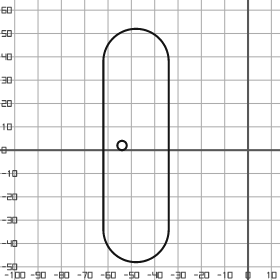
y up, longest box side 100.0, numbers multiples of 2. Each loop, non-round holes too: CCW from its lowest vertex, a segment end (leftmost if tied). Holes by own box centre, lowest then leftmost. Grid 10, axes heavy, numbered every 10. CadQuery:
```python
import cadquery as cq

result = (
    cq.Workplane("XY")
    .moveTo(-62.0, -34.0)
    .threePointArc((-48.0, -48.0), (-34.0, -34.0))
    .lineTo(-34.0, 38.0)
    .threePointArc((-48.0, 52.0), (-62.0, 38.0))
    .close()
    .moveTo(-54.0, 2.0)
    .circle(2.0)
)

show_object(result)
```